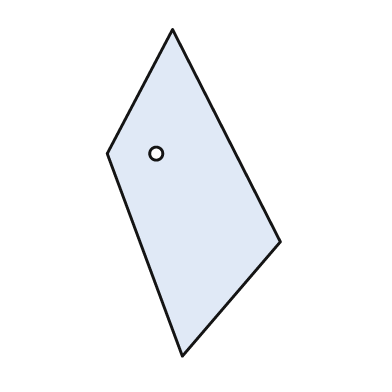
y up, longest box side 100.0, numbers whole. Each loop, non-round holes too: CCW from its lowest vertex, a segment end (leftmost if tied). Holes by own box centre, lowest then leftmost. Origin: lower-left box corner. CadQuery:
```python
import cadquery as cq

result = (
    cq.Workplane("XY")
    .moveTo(23.0, 0.0)
    .lineTo(53.0, 35.0)
    .lineTo(20.0, 100.0)
    .lineTo(0.0, 62.0)
    .close()
    .moveTo(15.0, 62.0)
    .circle(2.0)
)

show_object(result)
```